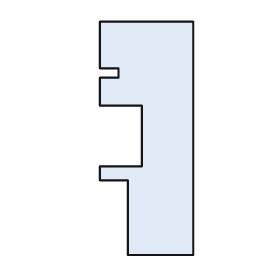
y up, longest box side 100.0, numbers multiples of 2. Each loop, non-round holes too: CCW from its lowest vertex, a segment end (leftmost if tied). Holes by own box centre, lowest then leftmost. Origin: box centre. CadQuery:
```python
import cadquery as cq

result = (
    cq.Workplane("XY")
    .moveTo(-8.0, -50.0)
    .lineTo(20.0, -50.0)
    .lineTo(20.0, 50.0)
    .lineTo(-20.0, 50.0)
    .lineTo(-20.0, 30.0)
    .lineTo(-12.0, 30.0)
    .lineTo(-12.0, 26.0)
    .lineTo(-20.0, 26.0)
    .lineTo(-20.0, 14.0)
    .lineTo(-2.0, 14.0)
    .lineTo(-2.0, -12.0)
    .lineTo(-20.0, -12.0)
    .lineTo(-20.0, -18.0)
    .lineTo(-8.0, -18.0)
    .close()
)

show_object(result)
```